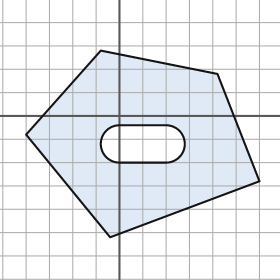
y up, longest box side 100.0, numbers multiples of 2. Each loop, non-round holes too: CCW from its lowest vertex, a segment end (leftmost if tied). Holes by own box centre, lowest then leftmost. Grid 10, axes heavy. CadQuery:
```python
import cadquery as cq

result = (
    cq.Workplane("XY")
    .moveTo(-4.0, -52.0)
    .lineTo(60.0, -28.0)
    .lineTo(42.0, 18.0)
    .lineTo(-8.0, 28.0)
    .lineTo(-40.0, -8.0)
    .close()
    .moveTo(0.0, -20.0)
    .lineTo(20.0, -20.0)
    .threePointArc((28.0, -12.0), (20.0, -4.0))
    .lineTo(0.0, -4.0)
    .threePointArc((-8.0, -12.0), (0.0, -20.0))
    .close()
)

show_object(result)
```